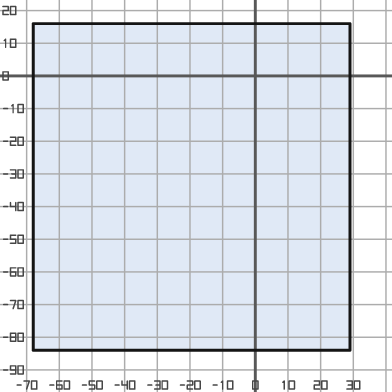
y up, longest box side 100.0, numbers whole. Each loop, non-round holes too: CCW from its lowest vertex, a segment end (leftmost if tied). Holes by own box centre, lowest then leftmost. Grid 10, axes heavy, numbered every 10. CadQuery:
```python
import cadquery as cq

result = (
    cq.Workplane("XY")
    .moveTo(-68.0, -84.0)
    .lineTo(29.0, -84.0)
    .lineTo(29.0, 16.0)
    .lineTo(-68.0, 16.0)
    .close()
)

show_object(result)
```